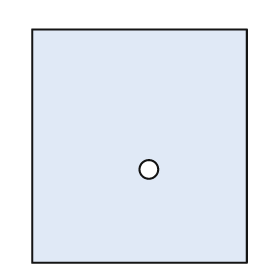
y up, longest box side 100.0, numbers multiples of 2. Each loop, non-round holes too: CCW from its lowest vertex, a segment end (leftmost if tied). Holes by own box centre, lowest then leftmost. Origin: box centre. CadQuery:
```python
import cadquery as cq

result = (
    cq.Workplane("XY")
    .moveTo(-46.0, -50.0)
    .lineTo(46.0, -50.0)
    .lineTo(46.0, 50.0)
    .lineTo(-46.0, 50.0)
    .close()
    .moveTo(4.0, -10.0)
    .circle(4.0)
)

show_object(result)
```